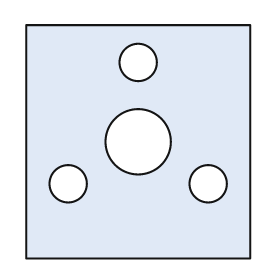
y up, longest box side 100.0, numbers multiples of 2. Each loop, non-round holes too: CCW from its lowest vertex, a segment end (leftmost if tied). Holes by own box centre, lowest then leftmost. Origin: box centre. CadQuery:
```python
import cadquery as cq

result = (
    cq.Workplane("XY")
    .moveTo(-48.0, -50.0)
    .lineTo(48.0, -50.0)
    .lineTo(48.0, 50.0)
    .lineTo(-48.0, 50.0)
    .close()
    .moveTo(-30.0, -18.0)
    .circle(8.0)
    .moveTo(30.0, -18.0)
    .circle(8.0)
    .moveTo(0.0, 0.0)
    .circle(14.0)
    .moveTo(0.0, 34.0)
    .circle(8.0)
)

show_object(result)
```